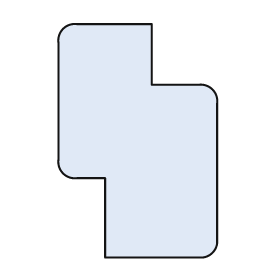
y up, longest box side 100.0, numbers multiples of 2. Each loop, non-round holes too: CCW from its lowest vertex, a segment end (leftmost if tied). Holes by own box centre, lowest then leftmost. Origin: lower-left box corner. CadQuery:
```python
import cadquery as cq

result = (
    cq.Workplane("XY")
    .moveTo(20.0, 0.0)
    .lineTo(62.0, 0.0)
    .threePointArc((66.0, 2.0), (68.0, 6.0))
    .lineTo(68.0, 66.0)
    .threePointArc((66.0, 72.0), (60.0, 74.0))
    .lineTo(40.0, 74.0)
    .lineTo(40.0, 100.0)
    .lineTo(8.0, 100.0)
    .threePointArc((2.0, 98.0), (0.0, 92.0))
    .lineTo(0.0, 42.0)
    .threePointArc((2.0, 36.0), (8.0, 34.0))
    .lineTo(20.0, 34.0)
    .close()
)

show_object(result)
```